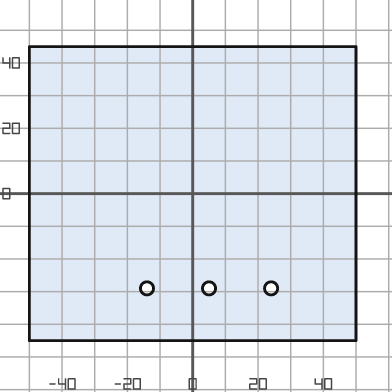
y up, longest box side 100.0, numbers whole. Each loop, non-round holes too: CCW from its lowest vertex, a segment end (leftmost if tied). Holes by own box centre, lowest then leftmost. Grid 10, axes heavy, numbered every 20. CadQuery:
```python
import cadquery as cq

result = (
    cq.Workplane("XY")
    .moveTo(-50.0, -45.0)
    .lineTo(50.0, -45.0)
    .lineTo(50.0, 45.0)
    .lineTo(-50.0, 45.0)
    .close()
    .moveTo(-14.0, -29.0)
    .circle(2.0)
    .moveTo(5.0, -29.0)
    .circle(2.0)
    .moveTo(24.0, -29.0)
    .circle(2.0)
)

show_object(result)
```